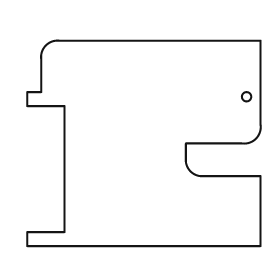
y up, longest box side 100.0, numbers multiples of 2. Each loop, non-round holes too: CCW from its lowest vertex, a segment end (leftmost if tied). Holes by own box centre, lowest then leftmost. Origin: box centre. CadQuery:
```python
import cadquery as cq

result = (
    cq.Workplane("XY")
    .moveTo(-50.0, -44.0)
    .lineTo(50.0, -44.0)
    .lineTo(50.0, -14.0)
    .lineTo(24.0, -14.0)
    .threePointArc((20.0, -12.0), (18.0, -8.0))
    .lineTo(18.0, 0.0)
    .lineTo(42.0, 0.0)
    .threePointArc((48.0, 2.0), (50.0, 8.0))
    .lineTo(50.0, 44.0)
    .lineTo(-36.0, 44.0)
    .threePointArc((-42.0, 42.0), (-44.0, 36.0))
    .lineTo(-44.0, 22.0)
    .lineTo(-50.0, 22.0)
    .lineTo(-50.0, 16.0)
    .lineTo(-34.0, 16.0)
    .lineTo(-34.0, -38.0)
    .lineTo(-50.0, -38.0)
    .close()
    .moveTo(44.0, 20.0)
    .circle(2.0)
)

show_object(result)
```